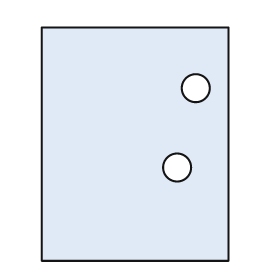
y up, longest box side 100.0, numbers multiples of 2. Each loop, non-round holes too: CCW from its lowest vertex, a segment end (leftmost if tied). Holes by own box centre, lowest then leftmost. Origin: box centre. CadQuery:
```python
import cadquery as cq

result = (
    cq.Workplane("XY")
    .moveTo(-40.0, -50.0)
    .lineTo(40.0, -50.0)
    .lineTo(40.0, 50.0)
    .lineTo(-40.0, 50.0)
    .close()
    .moveTo(18.0, -10.0)
    .circle(6.0)
    .moveTo(26.0, 24.0)
    .circle(6.0)
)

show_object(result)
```